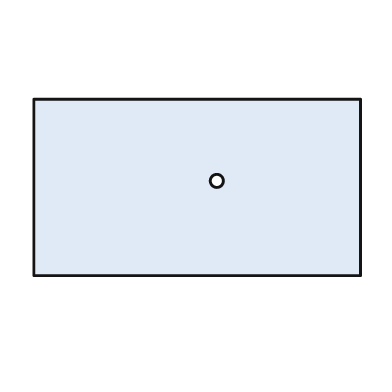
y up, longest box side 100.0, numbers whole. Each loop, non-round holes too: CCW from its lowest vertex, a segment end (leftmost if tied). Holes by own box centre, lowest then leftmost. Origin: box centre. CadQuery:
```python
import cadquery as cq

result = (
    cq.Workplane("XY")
    .moveTo(-50.0, -27.0)
    .lineTo(50.0, -27.0)
    .lineTo(50.0, 27.0)
    .lineTo(-50.0, 27.0)
    .close()
    .moveTo(6.0, 2.0)
    .circle(2.0)
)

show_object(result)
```